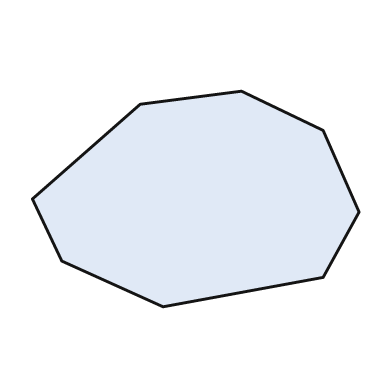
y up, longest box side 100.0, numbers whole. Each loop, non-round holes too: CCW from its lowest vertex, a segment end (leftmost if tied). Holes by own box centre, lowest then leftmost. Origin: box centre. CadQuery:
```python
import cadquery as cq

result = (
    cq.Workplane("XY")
    .moveTo(-10.0, -33.0)
    .lineTo(39.0, -24.0)
    .lineTo(50.0, -4.0)
    .lineTo(39.0, 21.0)
    .lineTo(14.0, 33.0)
    .lineTo(-17.0, 29.0)
    .lineTo(-50.0, 0.0)
    .lineTo(-41.0, -19.0)
    .close()
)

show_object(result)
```